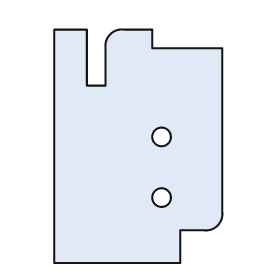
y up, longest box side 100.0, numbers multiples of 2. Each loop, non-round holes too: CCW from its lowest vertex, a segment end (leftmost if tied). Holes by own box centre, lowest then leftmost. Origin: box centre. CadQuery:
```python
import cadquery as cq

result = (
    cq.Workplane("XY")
    .moveTo(-36.0, -50.0)
    .lineTo(18.0, -50.0)
    .lineTo(18.0, -36.0)
    .lineTo(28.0, -36.0)
    .threePointArc((34.0, -34.0), (36.0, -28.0))
    .lineTo(36.0, 42.0)
    .lineTo(6.0, 42.0)
    .lineTo(6.0, 50.0)
    .lineTo(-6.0, 50.0)
    .threePointArc((-12.0, 48.0), (-14.0, 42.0))
    .lineTo(-14.0, 26.0)
    .lineTo(-22.0, 26.0)
    .lineTo(-22.0, 50.0)
    .lineTo(-36.0, 50.0)
    .close()
    .moveTo(10.0, -22.0)
    .circle(4.0)
    .moveTo(10.0, 4.0)
    .circle(4.0)
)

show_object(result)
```